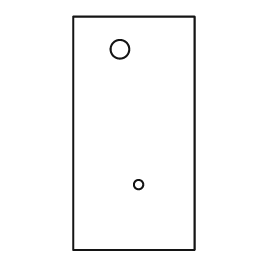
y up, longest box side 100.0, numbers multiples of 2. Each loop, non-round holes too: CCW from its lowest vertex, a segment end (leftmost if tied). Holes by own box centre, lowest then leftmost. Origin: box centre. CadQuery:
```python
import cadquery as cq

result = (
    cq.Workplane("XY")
    .moveTo(-26.0, -50.0)
    .lineTo(26.0, -50.0)
    .lineTo(26.0, 50.0)
    .lineTo(-26.0, 50.0)
    .close()
    .moveTo(2.0, -22.0)
    .circle(2.0)
    .moveTo(-6.0, 36.0)
    .circle(4.0)
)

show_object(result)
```